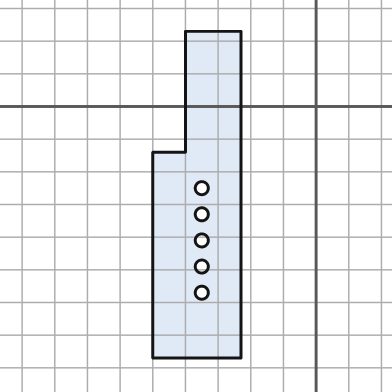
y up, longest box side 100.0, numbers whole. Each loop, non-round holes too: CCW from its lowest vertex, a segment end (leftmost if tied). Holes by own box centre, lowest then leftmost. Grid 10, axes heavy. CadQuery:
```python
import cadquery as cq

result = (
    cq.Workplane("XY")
    .moveTo(-50.0, -77.0)
    .lineTo(-23.0, -77.0)
    .lineTo(-23.0, 23.0)
    .lineTo(-40.0, 23.0)
    .lineTo(-40.0, -14.0)
    .lineTo(-50.0, -14.0)
    .close()
    .moveTo(-35.0, -57.0)
    .circle(2.0)
    .moveTo(-35.0, -49.0)
    .circle(2.0)
    .moveTo(-35.0, -41.0)
    .circle(2.0)
    .moveTo(-35.0, -33.0)
    .circle(2.0)
    .moveTo(-35.0, -25.0)
    .circle(2.0)
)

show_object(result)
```